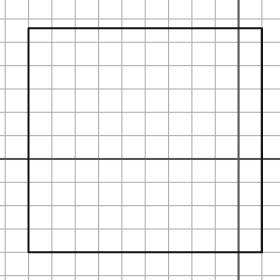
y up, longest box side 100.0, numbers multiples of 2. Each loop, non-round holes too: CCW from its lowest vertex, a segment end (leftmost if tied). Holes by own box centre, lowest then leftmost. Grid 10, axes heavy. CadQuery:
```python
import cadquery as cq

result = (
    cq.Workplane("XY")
    .moveTo(-90.0, -40.0)
    .lineTo(10.0, -40.0)
    .lineTo(10.0, 56.0)
    .lineTo(-90.0, 56.0)
    .close()
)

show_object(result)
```